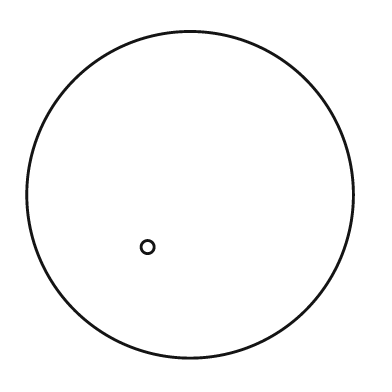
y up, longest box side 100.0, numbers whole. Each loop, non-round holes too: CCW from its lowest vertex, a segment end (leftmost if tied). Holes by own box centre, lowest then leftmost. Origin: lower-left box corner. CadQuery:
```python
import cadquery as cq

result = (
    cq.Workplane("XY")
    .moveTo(50.0, 50.0)
    .circle(50.0)
    .moveTo(37.0, 34.0)
    .circle(2.0)
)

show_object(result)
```